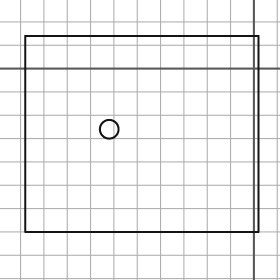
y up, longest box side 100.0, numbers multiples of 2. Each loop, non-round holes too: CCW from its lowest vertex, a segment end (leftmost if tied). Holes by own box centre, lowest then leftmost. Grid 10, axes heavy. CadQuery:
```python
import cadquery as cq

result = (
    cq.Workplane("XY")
    .moveTo(-98.0, -70.0)
    .lineTo(2.0, -70.0)
    .lineTo(2.0, 14.0)
    .lineTo(-98.0, 14.0)
    .close()
    .moveTo(-62.0, -26.0)
    .circle(4.0)
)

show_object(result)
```